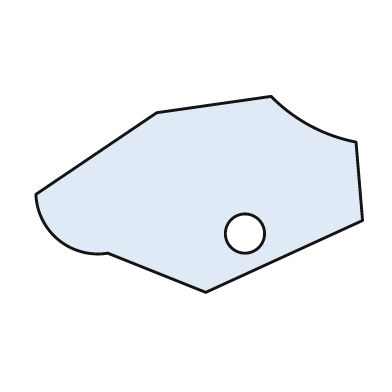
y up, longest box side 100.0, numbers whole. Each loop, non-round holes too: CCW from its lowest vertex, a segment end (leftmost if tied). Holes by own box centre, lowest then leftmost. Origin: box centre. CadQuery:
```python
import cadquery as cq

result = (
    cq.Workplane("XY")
    .moveTo(2.0, -30.0)
    .lineTo(50.0, -8.0)
    .lineTo(48.0, 16.0)
    .threePointArc((34.0, 21.0), (22.0, 30.0))
    .lineTo(-13.0, 25.0)
    .lineTo(-50.0, 0.0)
    .threePointArc((-43.0, -14.0), (-28.0, -18.0))
    .close()
    .moveTo(14.0, -12.0)
    .circle(6.0)
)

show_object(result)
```